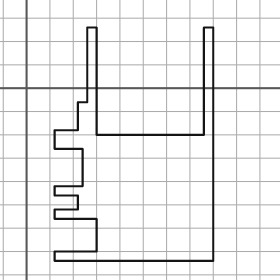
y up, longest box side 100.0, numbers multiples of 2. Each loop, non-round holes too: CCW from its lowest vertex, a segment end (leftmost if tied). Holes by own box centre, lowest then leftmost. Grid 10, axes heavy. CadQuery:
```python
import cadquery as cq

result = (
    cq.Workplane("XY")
    .moveTo(12.0, -74.0)
    .lineTo(80.0, -74.0)
    .lineTo(80.0, 26.0)
    .lineTo(76.0, 26.0)
    .lineTo(76.0, -20.0)
    .lineTo(30.0, -20.0)
    .lineTo(30.0, 26.0)
    .lineTo(26.0, 26.0)
    .lineTo(26.0, -6.0)
    .lineTo(22.0, -6.0)
    .lineTo(22.0, -18.0)
    .lineTo(12.0, -18.0)
    .lineTo(12.0, -26.0)
    .lineTo(24.0, -26.0)
    .lineTo(24.0, -42.0)
    .lineTo(12.0, -42.0)
    .lineTo(12.0, -46.0)
    .lineTo(22.0, -46.0)
    .lineTo(22.0, -52.0)
    .lineTo(12.0, -52.0)
    .lineTo(12.0, -56.0)
    .lineTo(30.0, -56.0)
    .lineTo(30.0, -70.0)
    .lineTo(12.0, -70.0)
    .close()
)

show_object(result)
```